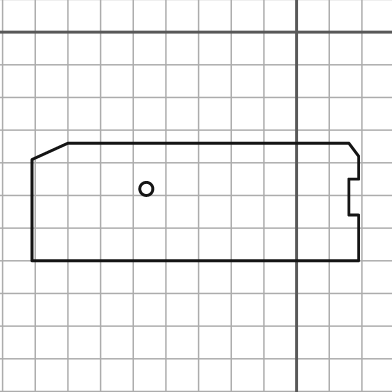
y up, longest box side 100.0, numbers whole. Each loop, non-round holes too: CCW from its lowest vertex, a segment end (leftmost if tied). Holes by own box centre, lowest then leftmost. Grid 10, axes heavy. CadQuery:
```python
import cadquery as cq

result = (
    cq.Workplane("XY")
    .moveTo(-81.0, -70.0)
    .lineTo(19.0, -70.0)
    .lineTo(19.0, -56.0)
    .lineTo(16.0, -56.0)
    .lineTo(16.0, -45.0)
    .lineTo(19.0, -45.0)
    .lineTo(19.0, -38.0)
    .lineTo(16.0, -34.0)
    .lineTo(-70.0, -34.0)
    .lineTo(-81.0, -39.0)
    .close()
    .moveTo(-46.0, -48.0)
    .circle(2.0)
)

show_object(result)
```